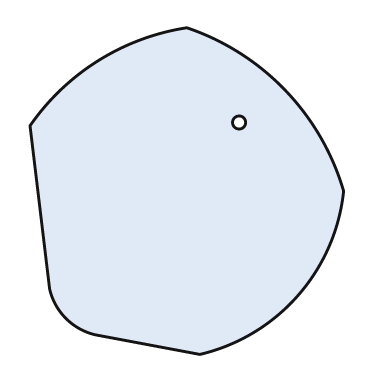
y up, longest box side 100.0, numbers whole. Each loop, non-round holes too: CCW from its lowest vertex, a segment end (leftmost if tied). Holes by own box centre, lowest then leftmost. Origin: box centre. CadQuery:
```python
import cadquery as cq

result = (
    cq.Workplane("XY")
    .moveTo(4.0, -50.0)
    .threePointArc((34.0, -32.0), (48.0, 0.0))
    .threePointArc((30.0, 31.0), (0.0, 50.0))
    .threePointArc((-27.0, 40.0), (-48.0, 20.0))
    .lineTo(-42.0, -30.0)
    .threePointArc((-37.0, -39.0), (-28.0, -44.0))
    .close()
    .moveTo(16.0, 21.0)
    .circle(2.0)
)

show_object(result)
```